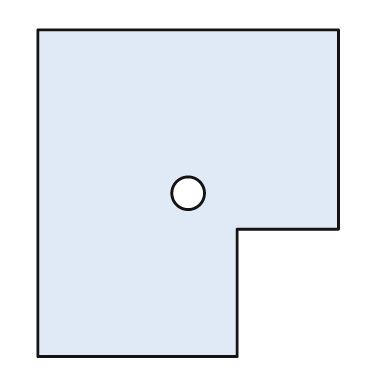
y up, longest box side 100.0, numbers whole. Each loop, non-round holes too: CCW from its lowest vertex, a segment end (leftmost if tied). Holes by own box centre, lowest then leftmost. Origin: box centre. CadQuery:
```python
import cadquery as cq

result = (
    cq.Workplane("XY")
    .moveTo(-46.0, -50.0)
    .lineTo(15.0, -50.0)
    .lineTo(15.0, -11.0)
    .lineTo(46.0, -11.0)
    .lineTo(46.0, 50.0)
    .lineTo(-46.0, 50.0)
    .close()
    .moveTo(0.0, 0.0)
    .circle(5.0)
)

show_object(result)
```